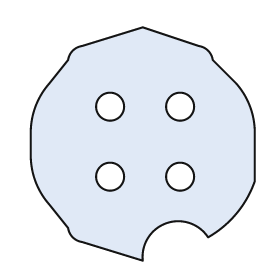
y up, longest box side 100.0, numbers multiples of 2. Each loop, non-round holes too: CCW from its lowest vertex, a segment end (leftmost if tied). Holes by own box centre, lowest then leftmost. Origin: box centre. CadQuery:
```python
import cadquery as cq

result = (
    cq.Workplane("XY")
    .moveTo(0.0, -50.0)
    .threePointArc((10.0, -34.0), (28.0, -40.0))
    .threePointArc((40.0, -30.0), (48.0, -16.0))
    .lineTo(48.0, 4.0)
    .threePointArc((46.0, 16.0), (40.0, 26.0))
    .lineTo(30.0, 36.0)
    .threePointArc((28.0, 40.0), (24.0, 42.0))
    .lineTo(0.0, 50.0)
    .lineTo(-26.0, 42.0)
    .threePointArc((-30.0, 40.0), (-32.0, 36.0))
    .lineTo(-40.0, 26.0)
    .threePointArc((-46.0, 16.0), (-48.0, 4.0))
    .lineTo(-48.0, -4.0)
    .threePointArc((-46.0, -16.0), (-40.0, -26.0))
    .lineTo(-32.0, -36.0)
    .threePointArc((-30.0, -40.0), (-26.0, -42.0))
    .close()
    .moveTo(-14.0, -14.0)
    .circle(6.0)
    .moveTo(16.0, -14.0)
    .circle(6.0)
    .moveTo(-14.0, 16.0)
    .circle(6.0)
    .moveTo(16.0, 16.0)
    .circle(6.0)
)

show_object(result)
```